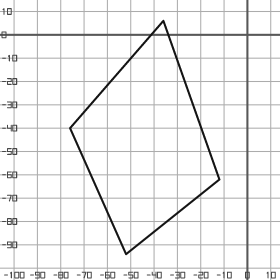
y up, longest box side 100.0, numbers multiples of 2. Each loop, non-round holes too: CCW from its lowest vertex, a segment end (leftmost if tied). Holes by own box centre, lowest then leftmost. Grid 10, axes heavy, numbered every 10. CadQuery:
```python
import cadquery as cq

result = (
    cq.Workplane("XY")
    .moveTo(-52.0, -94.0)
    .lineTo(-12.0, -62.0)
    .lineTo(-36.0, 6.0)
    .lineTo(-76.0, -40.0)
    .close()
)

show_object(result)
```